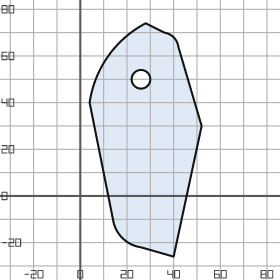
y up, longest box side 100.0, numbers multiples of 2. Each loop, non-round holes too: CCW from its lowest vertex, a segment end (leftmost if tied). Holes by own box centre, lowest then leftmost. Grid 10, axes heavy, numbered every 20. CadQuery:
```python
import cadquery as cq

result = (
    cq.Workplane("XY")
    .moveTo(40.0, -26.0)
    .lineTo(52.0, 30.0)
    .lineTo(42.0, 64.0)
    .threePointArc((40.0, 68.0), (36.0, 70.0))
    .lineTo(28.0, 74.0)
    .threePointArc((12.0, 60.0), (4.0, 40.0))
    .lineTo(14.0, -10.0)
    .threePointArc((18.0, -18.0), (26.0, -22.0))
    .close()
    .moveTo(26.0, 50.0)
    .circle(4.0)
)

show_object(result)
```